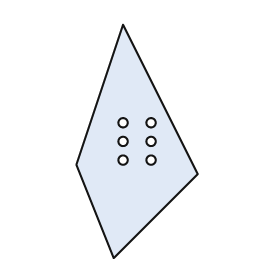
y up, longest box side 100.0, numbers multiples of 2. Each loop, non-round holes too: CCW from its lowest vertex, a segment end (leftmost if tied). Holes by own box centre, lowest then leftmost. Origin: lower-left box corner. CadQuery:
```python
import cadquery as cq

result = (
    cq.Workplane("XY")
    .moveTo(16.0, 0.0)
    .lineTo(52.0, 36.0)
    .lineTo(20.0, 100.0)
    .lineTo(0.0, 40.0)
    .close()
    .moveTo(20.0, 42.0)
    .circle(2.0)
    .moveTo(32.0, 42.0)
    .circle(2.0)
    .moveTo(20.0, 50.0)
    .circle(2.0)
    .moveTo(32.0, 50.0)
    .circle(2.0)
    .moveTo(20.0, 58.0)
    .circle(2.0)
    .moveTo(32.0, 58.0)
    .circle(2.0)
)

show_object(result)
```